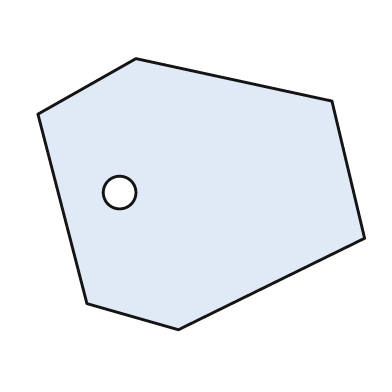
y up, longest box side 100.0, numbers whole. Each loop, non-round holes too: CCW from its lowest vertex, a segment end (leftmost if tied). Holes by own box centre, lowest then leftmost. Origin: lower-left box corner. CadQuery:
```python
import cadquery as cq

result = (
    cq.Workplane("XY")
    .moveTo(43.0, 0.0)
    .lineTo(100.0, 28.0)
    .lineTo(90.0, 70.0)
    .lineTo(30.0, 83.0)
    .lineTo(0.0, 66.0)
    .lineTo(15.0, 8.0)
    .close()
    .moveTo(25.0, 42.0)
    .circle(5.0)
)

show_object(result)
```